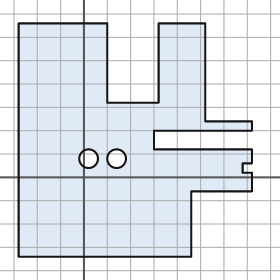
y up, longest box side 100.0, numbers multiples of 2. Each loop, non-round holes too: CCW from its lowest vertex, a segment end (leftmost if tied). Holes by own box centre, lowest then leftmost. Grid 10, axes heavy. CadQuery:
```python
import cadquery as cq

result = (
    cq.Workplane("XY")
    .moveTo(-28.0, -34.0)
    .lineTo(46.0, -34.0)
    .lineTo(46.0, -6.0)
    .lineTo(72.0, -6.0)
    .lineTo(72.0, 2.0)
    .lineTo(68.0, 2.0)
    .lineTo(68.0, 6.0)
    .lineTo(72.0, 6.0)
    .lineTo(72.0, 12.0)
    .lineTo(30.0, 12.0)
    .lineTo(30.0, 20.0)
    .lineTo(72.0, 20.0)
    .lineTo(72.0, 24.0)
    .lineTo(52.0, 24.0)
    .lineTo(52.0, 66.0)
    .lineTo(32.0, 66.0)
    .lineTo(32.0, 32.0)
    .lineTo(10.0, 32.0)
    .lineTo(10.0, 66.0)
    .lineTo(-28.0, 66.0)
    .close()
    .moveTo(2.0, 8.0)
    .circle(4.0)
    .moveTo(14.0, 8.0)
    .circle(4.0)
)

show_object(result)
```